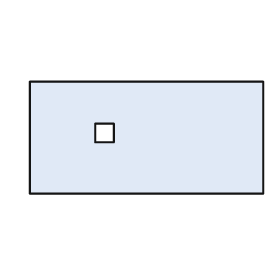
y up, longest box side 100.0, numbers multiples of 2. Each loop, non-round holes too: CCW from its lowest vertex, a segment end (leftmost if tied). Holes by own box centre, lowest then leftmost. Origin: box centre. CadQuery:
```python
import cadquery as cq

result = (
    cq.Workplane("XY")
    .moveTo(-50.0, -24.0)
    .lineTo(50.0, -24.0)
    .lineTo(50.0, 24.0)
    .lineTo(-50.0, 24.0)
    .close()
    .moveTo(-22.0, -2.0)
    .lineTo(-14.0, -2.0)
    .lineTo(-14.0, 6.0)
    .lineTo(-22.0, 6.0)
    .close()
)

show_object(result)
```